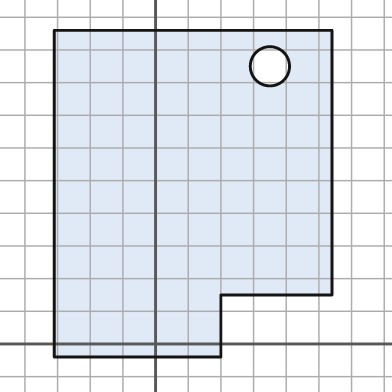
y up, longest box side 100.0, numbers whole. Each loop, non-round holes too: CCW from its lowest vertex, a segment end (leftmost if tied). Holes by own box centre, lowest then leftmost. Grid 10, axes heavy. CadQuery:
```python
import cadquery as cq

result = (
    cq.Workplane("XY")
    .moveTo(-31.0, -4.0)
    .lineTo(20.0, -4.0)
    .lineTo(20.0, 15.0)
    .lineTo(54.0, 15.0)
    .lineTo(54.0, 96.0)
    .lineTo(-31.0, 96.0)
    .close()
    .moveTo(35.0, 85.0)
    .circle(6.0)
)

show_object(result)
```